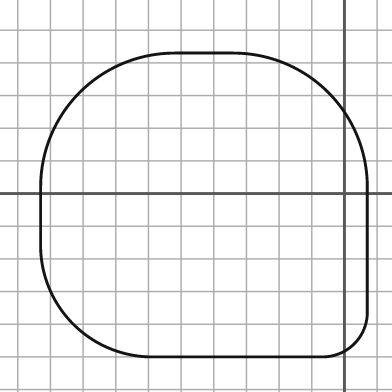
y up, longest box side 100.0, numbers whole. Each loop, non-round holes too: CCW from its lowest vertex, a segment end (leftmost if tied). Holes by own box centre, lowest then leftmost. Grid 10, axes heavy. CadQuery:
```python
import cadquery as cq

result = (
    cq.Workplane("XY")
    .moveTo(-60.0, -50.0)
    .lineTo(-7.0, -50.0)
    .threePointArc((3.0, -46.0), (7.0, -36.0))
    .lineTo(7.0, 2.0)
    .threePointArc((-5.0, 31.0), (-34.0, 43.0))
    .lineTo(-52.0, 43.0)
    .threePointArc((-81.0, 31.0), (-93.0, 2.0))
    .lineTo(-93.0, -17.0)
    .threePointArc((-83.0, -40.0), (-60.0, -50.0))
    .close()
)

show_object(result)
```